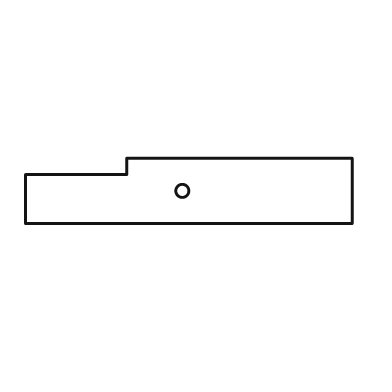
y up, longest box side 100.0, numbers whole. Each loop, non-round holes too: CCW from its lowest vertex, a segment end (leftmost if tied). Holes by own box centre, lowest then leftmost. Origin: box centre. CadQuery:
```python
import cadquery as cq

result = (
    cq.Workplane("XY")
    .moveTo(-50.0, -10.0)
    .lineTo(50.0, -10.0)
    .lineTo(50.0, 10.0)
    .lineTo(-19.0, 10.0)
    .lineTo(-19.0, 5.0)
    .lineTo(-50.0, 5.0)
    .close()
    .moveTo(-2.0, 0.0)
    .circle(2.0)
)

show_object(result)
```